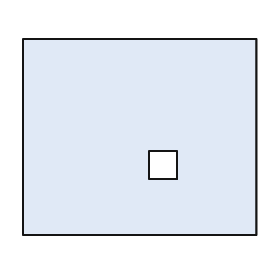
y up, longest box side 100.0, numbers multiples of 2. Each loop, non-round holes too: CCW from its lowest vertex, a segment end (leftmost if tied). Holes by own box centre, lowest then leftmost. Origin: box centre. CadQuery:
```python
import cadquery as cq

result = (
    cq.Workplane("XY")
    .moveTo(-50.0, -42.0)
    .lineTo(50.0, -42.0)
    .lineTo(50.0, 42.0)
    .lineTo(-50.0, 42.0)
    .close()
    .moveTo(4.0, -18.0)
    .lineTo(16.0, -18.0)
    .lineTo(16.0, -6.0)
    .lineTo(4.0, -6.0)
    .close()
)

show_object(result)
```